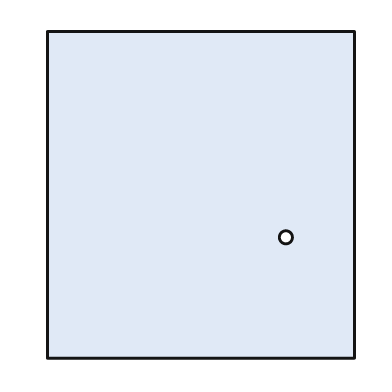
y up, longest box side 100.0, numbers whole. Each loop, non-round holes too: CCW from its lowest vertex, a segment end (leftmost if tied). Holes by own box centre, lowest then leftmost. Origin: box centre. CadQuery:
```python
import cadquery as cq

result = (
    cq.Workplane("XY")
    .moveTo(-47.0, -50.0)
    .lineTo(47.0, -50.0)
    .lineTo(47.0, 50.0)
    .lineTo(-47.0, 50.0)
    .close()
    .moveTo(26.0, -13.0)
    .circle(2.0)
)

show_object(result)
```